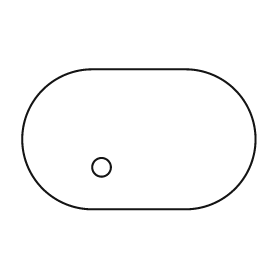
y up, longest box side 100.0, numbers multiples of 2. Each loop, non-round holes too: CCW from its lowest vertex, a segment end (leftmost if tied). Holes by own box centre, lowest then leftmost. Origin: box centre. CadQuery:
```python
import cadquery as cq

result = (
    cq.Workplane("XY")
    .moveTo(-20.0, -30.0)
    .lineTo(20.0, -30.0)
    .threePointArc((50.0, 0.0), (20.0, 30.0))
    .lineTo(-20.0, 30.0)
    .threePointArc((-50.0, 0.0), (-20.0, -30.0))
    .close()
    .moveTo(-16.0, -12.0)
    .circle(4.0)
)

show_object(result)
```